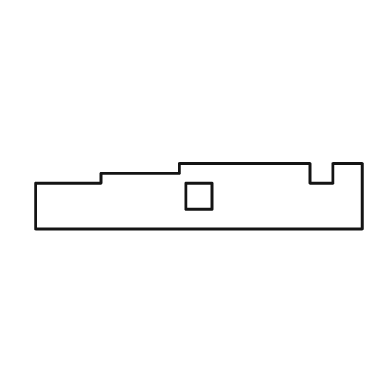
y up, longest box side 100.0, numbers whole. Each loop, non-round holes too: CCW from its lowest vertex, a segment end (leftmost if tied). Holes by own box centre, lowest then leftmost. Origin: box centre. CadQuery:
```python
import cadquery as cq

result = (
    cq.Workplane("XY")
    .moveTo(-50.0, -10.0)
    .lineTo(50.0, -10.0)
    .lineTo(50.0, 10.0)
    .lineTo(41.0, 10.0)
    .lineTo(41.0, 4.0)
    .lineTo(34.0, 4.0)
    .lineTo(34.0, 10.0)
    .lineTo(-6.0, 10.0)
    .lineTo(-6.0, 7.0)
    .lineTo(-30.0, 7.0)
    .lineTo(-30.0, 4.0)
    .lineTo(-50.0, 4.0)
    .close()
    .moveTo(-4.0, -4.0)
    .lineTo(4.0, -4.0)
    .lineTo(4.0, 4.0)
    .lineTo(-4.0, 4.0)
    .close()
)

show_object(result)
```